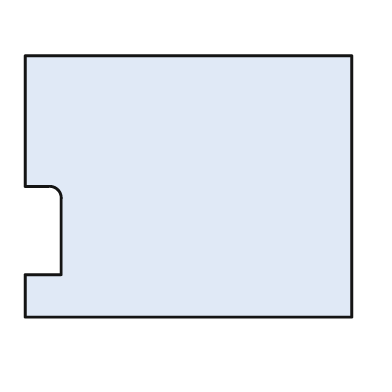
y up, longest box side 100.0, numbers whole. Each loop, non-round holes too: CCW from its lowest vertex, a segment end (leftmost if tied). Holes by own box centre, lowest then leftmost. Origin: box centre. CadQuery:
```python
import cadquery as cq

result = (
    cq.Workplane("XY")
    .moveTo(-50.0, -40.0)
    .lineTo(50.0, -40.0)
    .lineTo(50.0, 40.0)
    .lineTo(-50.0, 40.0)
    .lineTo(-50.0, 0.0)
    .lineTo(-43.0, 0.0)
    .threePointArc((-40.0, -1.0), (-39.0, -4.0))
    .lineTo(-39.0, -27.0)
    .lineTo(-50.0, -27.0)
    .close()
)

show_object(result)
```